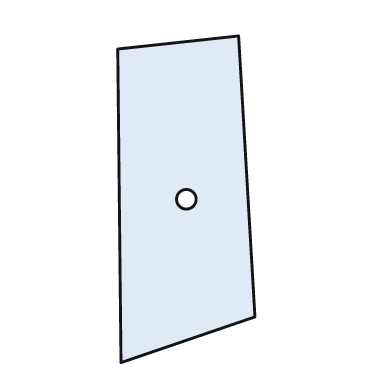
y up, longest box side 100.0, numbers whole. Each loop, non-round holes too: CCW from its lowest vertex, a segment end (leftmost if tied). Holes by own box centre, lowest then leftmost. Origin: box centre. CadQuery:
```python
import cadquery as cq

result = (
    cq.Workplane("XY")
    .moveTo(-20.0, -50.0)
    .lineTo(21.0, -36.0)
    .lineTo(16.0, 50.0)
    .lineTo(-21.0, 46.0)
    .close()
    .moveTo(0.0, 0.0)
    .circle(3.0)
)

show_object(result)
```